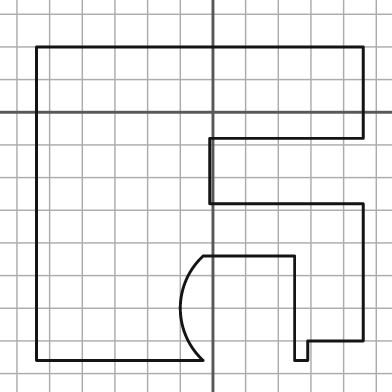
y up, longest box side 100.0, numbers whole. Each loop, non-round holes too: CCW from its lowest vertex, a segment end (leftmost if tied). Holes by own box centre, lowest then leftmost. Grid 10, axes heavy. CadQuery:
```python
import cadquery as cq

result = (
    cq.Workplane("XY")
    .moveTo(-54.0, -76.0)
    .lineTo(-3.0, -76.0)
    .threePointArc((-10.0, -60.0), (-3.0, -44.0))
    .lineTo(25.0, -44.0)
    .lineTo(25.0, -76.0)
    .lineTo(29.0, -76.0)
    .lineTo(29.0, -70.0)
    .lineTo(46.0, -70.0)
    .lineTo(46.0, -28.0)
    .lineTo(-1.0, -28.0)
    .lineTo(-1.0, -8.0)
    .lineTo(46.0, -8.0)
    .lineTo(46.0, 20.0)
    .lineTo(-54.0, 20.0)
    .close()
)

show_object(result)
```